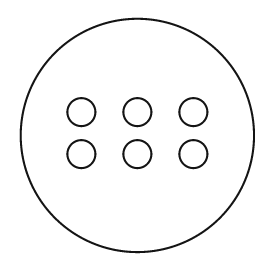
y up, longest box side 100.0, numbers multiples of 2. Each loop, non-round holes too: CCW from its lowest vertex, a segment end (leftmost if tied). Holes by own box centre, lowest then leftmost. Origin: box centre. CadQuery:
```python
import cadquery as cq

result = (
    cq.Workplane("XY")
    .moveTo(0.0, 0.0)
    .circle(50.0)
    .moveTo(-24.0, -8.0)
    .circle(6.0)
    .moveTo(0.0, -8.0)
    .circle(6.0)
    .moveTo(24.0, -8.0)
    .circle(6.0)
    .moveTo(-24.0, 10.0)
    .circle(6.0)
    .moveTo(0.0, 10.0)
    .circle(6.0)
    .moveTo(24.0, 10.0)
    .circle(6.0)
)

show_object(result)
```